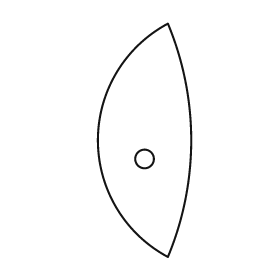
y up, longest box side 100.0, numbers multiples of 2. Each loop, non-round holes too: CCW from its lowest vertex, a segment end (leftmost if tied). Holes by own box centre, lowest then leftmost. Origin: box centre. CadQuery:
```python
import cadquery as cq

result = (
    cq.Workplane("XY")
    .moveTo(10.0, -50.0)
    .threePointArc((20.0, 0.0), (10.0, 50.0))
    .threePointArc((-20.0, 0.0), (10.0, -50.0))
    .close()
    .moveTo(0.0, -8.0)
    .circle(4.0)
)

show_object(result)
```